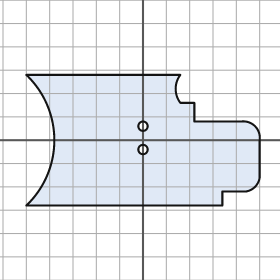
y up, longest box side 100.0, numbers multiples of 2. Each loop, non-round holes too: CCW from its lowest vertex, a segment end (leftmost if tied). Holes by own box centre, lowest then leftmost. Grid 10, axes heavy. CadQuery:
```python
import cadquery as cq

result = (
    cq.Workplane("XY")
    .moveTo(-50.0, -28.0)
    .lineTo(34.0, -28.0)
    .lineTo(34.0, -22.0)
    .lineTo(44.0, -22.0)
    .threePointArc((48.0, -20.0), (50.0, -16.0))
    .lineTo(50.0, 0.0)
    .threePointArc((48.0, 6.0), (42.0, 8.0))
    .lineTo(22.0, 8.0)
    .lineTo(22.0, 16.0)
    .lineTo(16.0, 16.0)
    .threePointArc((14.0, 22.0), (16.0, 28.0))
    .lineTo(-50.0, 28.0)
    .threePointArc((-38.0, 0.0), (-50.0, -28.0))
    .close()
    .moveTo(0.0, -4.0)
    .circle(2.0)
    .moveTo(0.0, 6.0)
    .circle(2.0)
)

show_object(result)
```